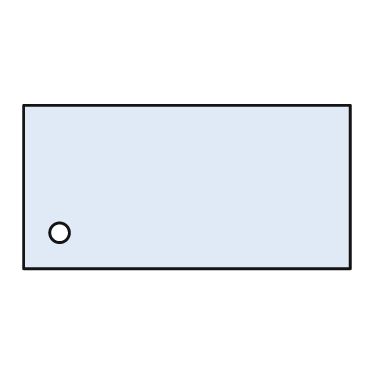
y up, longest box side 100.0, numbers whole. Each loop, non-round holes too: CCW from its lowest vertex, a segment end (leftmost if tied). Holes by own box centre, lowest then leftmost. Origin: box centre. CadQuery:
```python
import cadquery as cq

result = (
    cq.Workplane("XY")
    .moveTo(-50.0, -25.0)
    .lineTo(50.0, -25.0)
    .lineTo(50.0, 25.0)
    .lineTo(-50.0, 25.0)
    .close()
    .moveTo(-39.0, -14.0)
    .circle(3.0)
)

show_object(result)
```